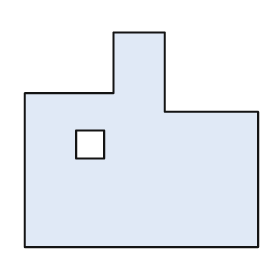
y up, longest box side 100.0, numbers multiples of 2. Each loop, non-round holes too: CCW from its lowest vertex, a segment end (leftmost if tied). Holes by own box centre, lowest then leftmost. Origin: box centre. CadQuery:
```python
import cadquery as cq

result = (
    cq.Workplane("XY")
    .moveTo(-50.0, -46.0)
    .lineTo(50.0, -46.0)
    .lineTo(50.0, 12.0)
    .lineTo(10.0, 12.0)
    .lineTo(10.0, 46.0)
    .lineTo(-12.0, 46.0)
    .lineTo(-12.0, 20.0)
    .lineTo(-50.0, 20.0)
    .close()
    .moveTo(-28.0, -8.0)
    .lineTo(-16.0, -8.0)
    .lineTo(-16.0, 4.0)
    .lineTo(-28.0, 4.0)
    .close()
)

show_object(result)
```